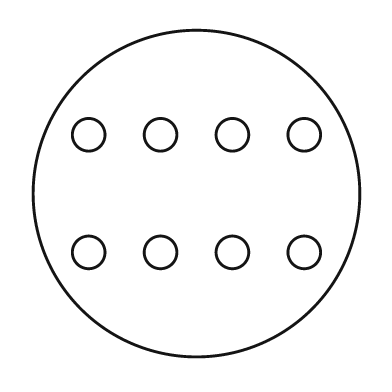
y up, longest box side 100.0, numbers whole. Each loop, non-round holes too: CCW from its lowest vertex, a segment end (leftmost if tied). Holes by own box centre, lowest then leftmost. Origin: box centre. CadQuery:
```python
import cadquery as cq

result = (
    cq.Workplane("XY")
    .moveTo(0.0, 0.0)
    .circle(50.0)
    .moveTo(-33.0, -18.0)
    .circle(5.0)
    .moveTo(-11.0, -18.0)
    .circle(5.0)
    .moveTo(11.0, -18.0)
    .circle(5.0)
    .moveTo(33.0, -18.0)
    .circle(5.0)
    .moveTo(-33.0, 18.0)
    .circle(5.0)
    .moveTo(-11.0, 18.0)
    .circle(5.0)
    .moveTo(11.0, 18.0)
    .circle(5.0)
    .moveTo(33.0, 18.0)
    .circle(5.0)
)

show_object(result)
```